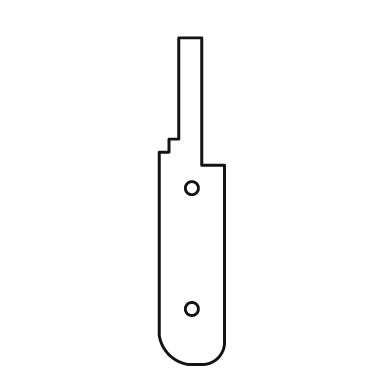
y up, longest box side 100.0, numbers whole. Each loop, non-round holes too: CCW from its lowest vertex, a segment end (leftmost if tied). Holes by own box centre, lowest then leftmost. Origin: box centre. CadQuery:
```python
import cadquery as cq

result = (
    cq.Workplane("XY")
    .moveTo(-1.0, -50.0)
    .lineTo(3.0, -50.0)
    .threePointArc((8.0, -48.0), (10.0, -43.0))
    .lineTo(10.0, 11.0)
    .lineTo(3.0, 11.0)
    .lineTo(3.0, 50.0)
    .lineTo(-4.0, 50.0)
    .lineTo(-4.0, 19.0)
    .lineTo(-7.0, 19.0)
    .lineTo(-7.0, 15.0)
    .lineTo(-10.0, 15.0)
    .lineTo(-10.0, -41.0)
    .threePointArc((-7.0, -47.0), (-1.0, -50.0))
    .close()
    .moveTo(0.0, -33.0)
    .circle(2.0)
    .moveTo(0.0, 4.0)
    .circle(2.0)
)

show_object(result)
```